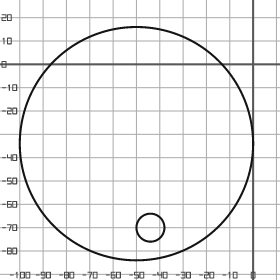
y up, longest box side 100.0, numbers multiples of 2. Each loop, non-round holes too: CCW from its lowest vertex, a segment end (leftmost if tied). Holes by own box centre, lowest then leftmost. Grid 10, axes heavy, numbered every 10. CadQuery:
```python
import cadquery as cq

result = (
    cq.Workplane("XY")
    .moveTo(-50.0, -34.0)
    .circle(50.0)
    .moveTo(-44.0, -70.0)
    .circle(6.0)
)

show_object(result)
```